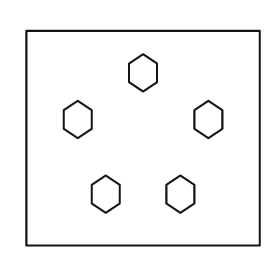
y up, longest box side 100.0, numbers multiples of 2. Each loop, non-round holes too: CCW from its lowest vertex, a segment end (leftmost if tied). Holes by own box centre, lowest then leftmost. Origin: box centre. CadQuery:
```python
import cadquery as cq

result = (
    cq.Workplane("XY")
    .moveTo(-50.0, -46.0)
    .lineTo(50.0, -46.0)
    .lineTo(50.0, 46.0)
    .lineTo(-50.0, 46.0)
    .close()
    .moveTo(-16.0, -32.0)
    .lineTo(-10.0, -28.0)
    .lineTo(-10.0, -20.0)
    .lineTo(-16.0, -16.0)
    .lineTo(-22.0, -20.0)
    .lineTo(-22.0, -28.0)
    .close()
    .moveTo(16.0, -32.0)
    .lineTo(22.0, -28.0)
    .lineTo(22.0, -20.0)
    .lineTo(16.0, -16.0)
    .lineTo(10.0, -20.0)
    .lineTo(10.0, -28.0)
    .close()
    .moveTo(-28.0, 0.0)
    .lineTo(-22.0, 4.0)
    .lineTo(-22.0, 12.0)
    .lineTo(-28.0, 16.0)
    .lineTo(-34.0, 12.0)
    .lineTo(-34.0, 4.0)
    .close()
    .moveTo(28.0, 0.0)
    .lineTo(34.0, 4.0)
    .lineTo(34.0, 12.0)
    .lineTo(28.0, 16.0)
    .lineTo(22.0, 12.0)
    .lineTo(22.0, 4.0)
    .close()
    .moveTo(0.0, 20.0)
    .lineTo(6.0, 24.0)
    .lineTo(6.0, 32.0)
    .lineTo(0.0, 36.0)
    .lineTo(-6.0, 32.0)
    .lineTo(-6.0, 24.0)
    .close()
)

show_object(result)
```